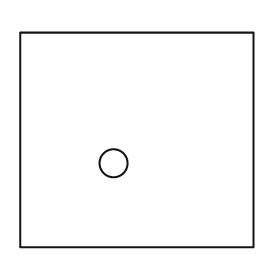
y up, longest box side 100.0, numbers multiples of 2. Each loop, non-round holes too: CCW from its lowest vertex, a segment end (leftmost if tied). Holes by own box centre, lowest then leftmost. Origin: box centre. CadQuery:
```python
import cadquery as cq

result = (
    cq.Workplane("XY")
    .moveTo(-50.0, -46.0)
    .lineTo(50.0, -46.0)
    .lineTo(50.0, 46.0)
    .lineTo(-50.0, 46.0)
    .close()
    .moveTo(-10.0, -10.0)
    .circle(6.0)
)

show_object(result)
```